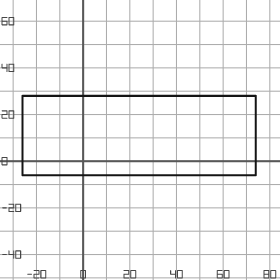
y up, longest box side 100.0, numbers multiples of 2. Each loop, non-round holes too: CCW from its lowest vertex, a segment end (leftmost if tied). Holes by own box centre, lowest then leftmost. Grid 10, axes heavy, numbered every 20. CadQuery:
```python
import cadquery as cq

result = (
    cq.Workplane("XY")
    .moveTo(-26.0, -6.0)
    .lineTo(74.0, -6.0)
    .lineTo(74.0, 28.0)
    .lineTo(-26.0, 28.0)
    .close()
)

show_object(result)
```